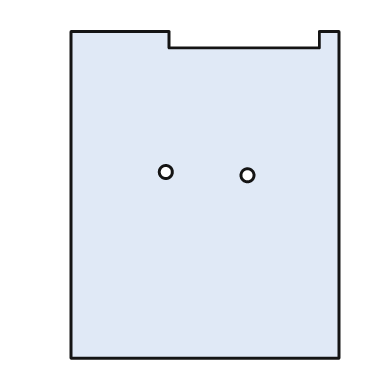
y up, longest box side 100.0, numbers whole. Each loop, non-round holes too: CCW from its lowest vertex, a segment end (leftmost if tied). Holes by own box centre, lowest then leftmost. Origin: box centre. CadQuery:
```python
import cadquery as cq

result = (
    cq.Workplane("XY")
    .moveTo(-41.0, -50.0)
    .lineTo(41.0, -50.0)
    .lineTo(41.0, 50.0)
    .lineTo(35.0, 50.0)
    .lineTo(35.0, 45.0)
    .lineTo(-11.0, 45.0)
    .lineTo(-11.0, 50.0)
    .lineTo(-41.0, 50.0)
    .close()
    .moveTo(13.0, 6.0)
    .circle(2.0)
    .moveTo(-12.0, 7.0)
    .circle(2.0)
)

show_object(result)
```